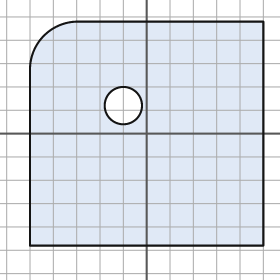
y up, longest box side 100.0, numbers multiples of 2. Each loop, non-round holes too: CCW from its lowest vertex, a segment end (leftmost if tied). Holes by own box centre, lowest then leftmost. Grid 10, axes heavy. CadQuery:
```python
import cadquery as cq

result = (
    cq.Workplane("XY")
    .moveTo(-50.0, -48.0)
    .lineTo(50.0, -48.0)
    .lineTo(50.0, 48.0)
    .lineTo(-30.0, 48.0)
    .threePointArc((-44.0, 42.0), (-50.0, 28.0))
    .close()
    .moveTo(-10.0, 12.0)
    .circle(8.0)
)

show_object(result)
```